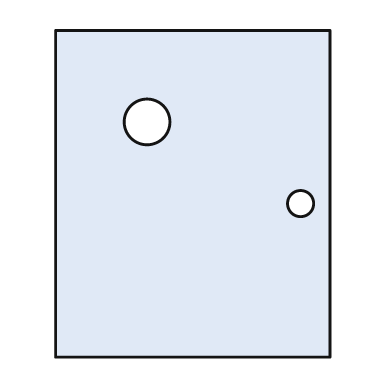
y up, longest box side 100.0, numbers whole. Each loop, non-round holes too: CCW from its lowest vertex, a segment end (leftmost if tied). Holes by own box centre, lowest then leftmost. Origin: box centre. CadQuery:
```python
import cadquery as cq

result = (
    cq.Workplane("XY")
    .moveTo(-42.0, -50.0)
    .lineTo(42.0, -50.0)
    .lineTo(42.0, 50.0)
    .lineTo(-42.0, 50.0)
    .close()
    .moveTo(33.0, -3.0)
    .circle(4.0)
    .moveTo(-14.0, 22.0)
    .circle(7.0)
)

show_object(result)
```